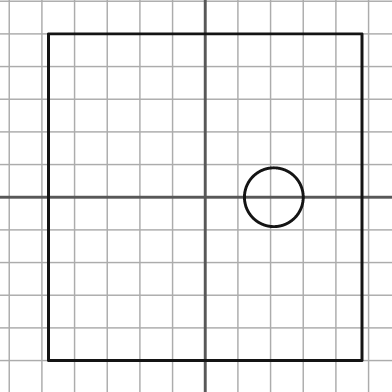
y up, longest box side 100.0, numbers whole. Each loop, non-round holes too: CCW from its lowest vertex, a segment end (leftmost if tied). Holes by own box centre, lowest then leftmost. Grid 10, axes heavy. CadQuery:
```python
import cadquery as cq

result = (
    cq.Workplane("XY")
    .moveTo(-48.0, -50.0)
    .lineTo(48.0, -50.0)
    .lineTo(48.0, 50.0)
    .lineTo(-48.0, 50.0)
    .close()
    .moveTo(21.0, 0.0)
    .circle(9.0)
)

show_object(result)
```